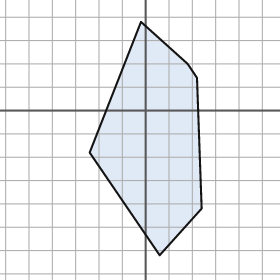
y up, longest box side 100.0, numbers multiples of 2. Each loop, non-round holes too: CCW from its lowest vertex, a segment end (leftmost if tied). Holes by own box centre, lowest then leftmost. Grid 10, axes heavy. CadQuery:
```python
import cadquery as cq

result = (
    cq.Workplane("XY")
    .moveTo(6.0, -62.0)
    .lineTo(24.0, -42.0)
    .lineTo(22.0, 14.0)
    .lineTo(18.0, 20.0)
    .lineTo(-2.0, 38.0)
    .lineTo(-24.0, -18.0)
    .close()
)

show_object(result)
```